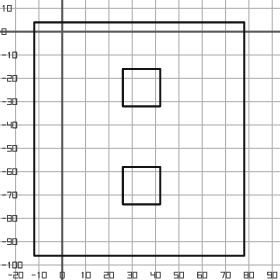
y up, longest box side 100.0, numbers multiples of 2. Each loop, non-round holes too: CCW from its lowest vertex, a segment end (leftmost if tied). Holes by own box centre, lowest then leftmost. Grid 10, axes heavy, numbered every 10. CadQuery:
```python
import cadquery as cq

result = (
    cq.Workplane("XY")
    .moveTo(-12.0, -96.0)
    .lineTo(78.0, -96.0)
    .lineTo(78.0, 4.0)
    .lineTo(-12.0, 4.0)
    .close()
    .moveTo(26.0, -74.0)
    .lineTo(42.0, -74.0)
    .lineTo(42.0, -58.0)
    .lineTo(26.0, -58.0)
    .close()
    .moveTo(26.0, -32.0)
    .lineTo(42.0, -32.0)
    .lineTo(42.0, -16.0)
    .lineTo(26.0, -16.0)
    .close()
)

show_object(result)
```